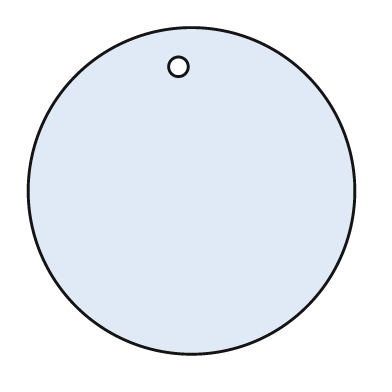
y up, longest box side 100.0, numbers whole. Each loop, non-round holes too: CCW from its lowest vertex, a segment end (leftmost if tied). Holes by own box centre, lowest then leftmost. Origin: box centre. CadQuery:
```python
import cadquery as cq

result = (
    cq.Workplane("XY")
    .moveTo(0.0, 0.0)
    .circle(50.0)
    .moveTo(-4.0, 38.0)
    .circle(3.0)
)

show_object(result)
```